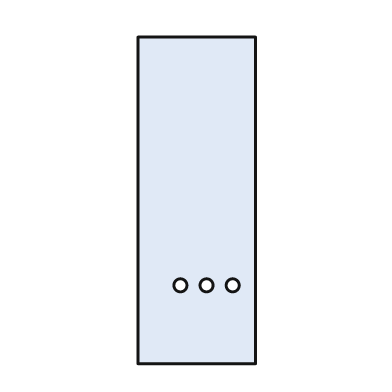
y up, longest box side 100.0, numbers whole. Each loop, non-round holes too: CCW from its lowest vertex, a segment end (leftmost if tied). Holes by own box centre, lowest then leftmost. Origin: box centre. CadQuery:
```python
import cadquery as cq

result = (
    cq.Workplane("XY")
    .moveTo(-18.0, -50.0)
    .lineTo(18.0, -50.0)
    .lineTo(18.0, 50.0)
    .lineTo(-18.0, 50.0)
    .close()
    .moveTo(-5.0, -26.0)
    .circle(2.0)
    .moveTo(3.0, -26.0)
    .circle(2.0)
    .moveTo(11.0, -26.0)
    .circle(2.0)
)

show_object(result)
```